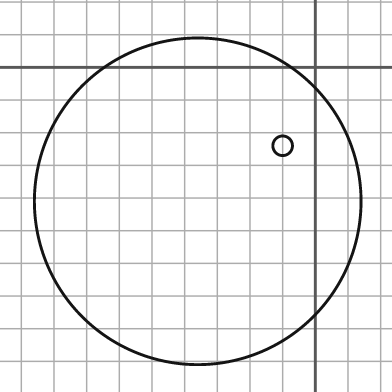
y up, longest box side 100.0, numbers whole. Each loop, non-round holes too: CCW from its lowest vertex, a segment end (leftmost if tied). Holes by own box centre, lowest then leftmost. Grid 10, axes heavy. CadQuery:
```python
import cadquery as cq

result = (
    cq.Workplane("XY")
    .moveTo(-36.0, -41.0)
    .circle(50.0)
    .moveTo(-10.0, -24.0)
    .circle(3.0)
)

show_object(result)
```